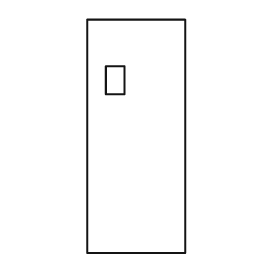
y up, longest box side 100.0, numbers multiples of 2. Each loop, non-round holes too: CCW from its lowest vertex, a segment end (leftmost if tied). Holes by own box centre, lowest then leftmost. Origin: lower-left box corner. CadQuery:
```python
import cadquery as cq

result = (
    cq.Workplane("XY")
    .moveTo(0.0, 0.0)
    .lineTo(42.0, 0.0)
    .lineTo(42.0, 100.0)
    .lineTo(0.0, 100.0)
    .close()
    .moveTo(8.0, 68.0)
    .lineTo(16.0, 68.0)
    .lineTo(16.0, 80.0)
    .lineTo(8.0, 80.0)
    .close()
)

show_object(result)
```